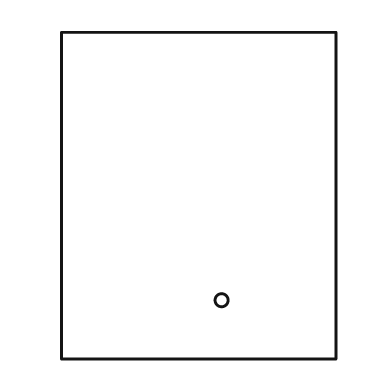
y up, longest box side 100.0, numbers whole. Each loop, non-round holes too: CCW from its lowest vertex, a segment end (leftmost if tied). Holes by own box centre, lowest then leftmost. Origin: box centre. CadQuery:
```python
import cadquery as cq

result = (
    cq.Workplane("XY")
    .moveTo(-42.0, -50.0)
    .lineTo(42.0, -50.0)
    .lineTo(42.0, 50.0)
    .lineTo(-42.0, 50.0)
    .close()
    .moveTo(7.0, -32.0)
    .circle(2.0)
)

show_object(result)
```